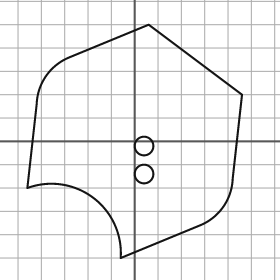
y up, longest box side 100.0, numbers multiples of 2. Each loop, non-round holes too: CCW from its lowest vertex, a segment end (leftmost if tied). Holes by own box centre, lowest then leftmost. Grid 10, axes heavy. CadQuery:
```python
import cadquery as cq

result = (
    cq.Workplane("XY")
    .moveTo(-6.0, -50.0)
    .lineTo(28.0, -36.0)
    .threePointArc((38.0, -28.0), (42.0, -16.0))
    .lineTo(46.0, 20.0)
    .lineTo(6.0, 50.0)
    .lineTo(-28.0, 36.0)
    .threePointArc((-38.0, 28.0), (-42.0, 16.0))
    .lineTo(-46.0, -20.0)
    .threePointArc((-18.0, -24.0), (-6.0, -50.0))
    .close()
    .moveTo(4.0, -14.0)
    .circle(4.0)
    .moveTo(4.0, -2.0)
    .circle(4.0)
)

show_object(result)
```